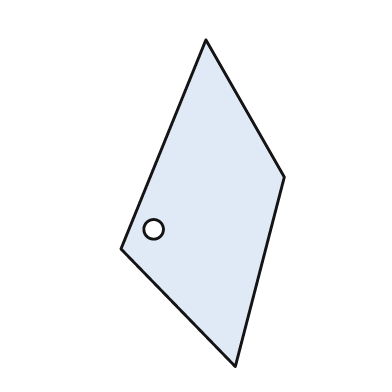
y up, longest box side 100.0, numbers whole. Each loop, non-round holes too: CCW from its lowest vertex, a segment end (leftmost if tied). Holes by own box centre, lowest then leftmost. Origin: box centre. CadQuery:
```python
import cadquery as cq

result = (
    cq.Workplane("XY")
    .moveTo(10.0, -50.0)
    .lineTo(25.0, 8.0)
    .lineTo(1.0, 50.0)
    .lineTo(-25.0, -14.0)
    .close()
    .moveTo(-15.0, -8.0)
    .circle(3.0)
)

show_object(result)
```